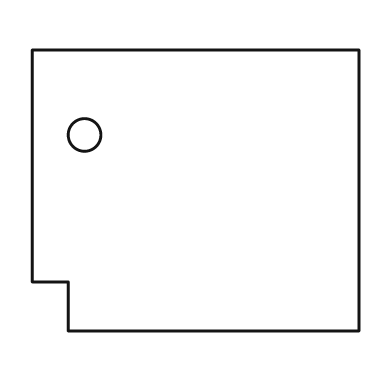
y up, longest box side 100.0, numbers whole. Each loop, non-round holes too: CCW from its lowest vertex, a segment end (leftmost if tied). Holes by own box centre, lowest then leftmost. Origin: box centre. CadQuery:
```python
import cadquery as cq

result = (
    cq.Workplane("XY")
    .moveTo(-39.0, -43.0)
    .lineTo(50.0, -43.0)
    .lineTo(50.0, 43.0)
    .lineTo(-50.0, 43.0)
    .lineTo(-50.0, -28.0)
    .lineTo(-39.0, -28.0)
    .close()
    .moveTo(-34.0, 17.0)
    .circle(5.0)
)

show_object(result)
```